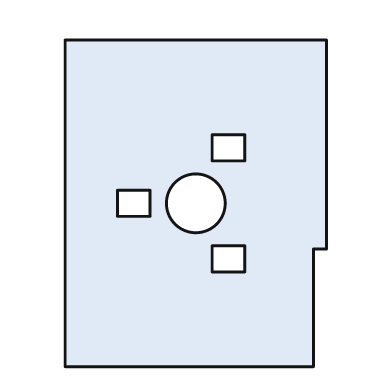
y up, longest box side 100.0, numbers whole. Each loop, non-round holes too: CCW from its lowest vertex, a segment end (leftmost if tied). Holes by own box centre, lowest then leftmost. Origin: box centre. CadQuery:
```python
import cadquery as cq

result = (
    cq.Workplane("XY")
    .moveTo(-40.0, -50.0)
    .lineTo(36.0, -50.0)
    .lineTo(36.0, -14.0)
    .lineTo(40.0, -14.0)
    .lineTo(40.0, 50.0)
    .lineTo(-40.0, 50.0)
    .close()
    .moveTo(5.0, -21.0)
    .lineTo(15.0, -21.0)
    .lineTo(15.0, -13.0)
    .lineTo(5.0, -13.0)
    .close()
    .moveTo(-24.0, -4.0)
    .lineTo(-14.0, -4.0)
    .lineTo(-14.0, 4.0)
    .lineTo(-24.0, 4.0)
    .close()
    .moveTo(0.0, 0.0)
    .circle(9.0)
    .moveTo(5.0, 13.0)
    .lineTo(15.0, 13.0)
    .lineTo(15.0, 21.0)
    .lineTo(5.0, 21.0)
    .close()
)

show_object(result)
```